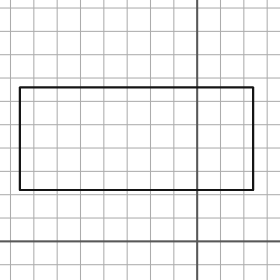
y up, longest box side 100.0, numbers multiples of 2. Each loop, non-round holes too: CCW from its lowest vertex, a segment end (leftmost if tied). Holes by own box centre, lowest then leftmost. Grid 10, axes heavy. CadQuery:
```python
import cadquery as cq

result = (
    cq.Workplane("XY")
    .moveTo(-76.0, 22.0)
    .lineTo(24.0, 22.0)
    .lineTo(24.0, 66.0)
    .lineTo(-76.0, 66.0)
    .close()
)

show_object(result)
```